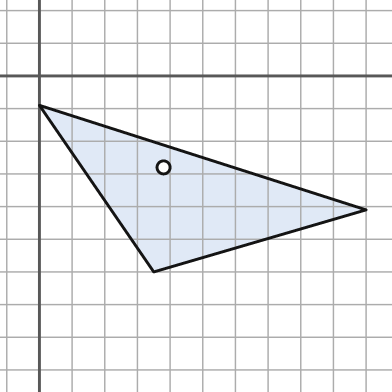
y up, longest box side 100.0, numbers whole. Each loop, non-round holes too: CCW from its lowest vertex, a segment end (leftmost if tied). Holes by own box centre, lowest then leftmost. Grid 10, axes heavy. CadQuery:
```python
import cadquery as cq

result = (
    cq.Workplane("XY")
    .moveTo(35.0, -60.0)
    .lineTo(100.0, -41.0)
    .lineTo(0.0, -9.0)
    .close()
    .moveTo(38.0, -28.0)
    .circle(2.0)
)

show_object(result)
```